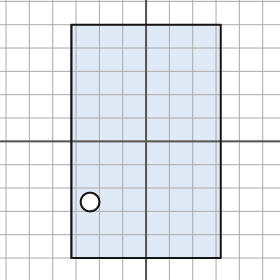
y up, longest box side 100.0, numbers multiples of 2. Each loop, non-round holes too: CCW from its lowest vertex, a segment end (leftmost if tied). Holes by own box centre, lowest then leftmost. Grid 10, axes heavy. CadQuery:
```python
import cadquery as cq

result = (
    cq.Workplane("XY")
    .moveTo(-32.0, -50.0)
    .lineTo(32.0, -50.0)
    .lineTo(32.0, 50.0)
    .lineTo(-32.0, 50.0)
    .close()
    .moveTo(-24.0, -26.0)
    .circle(4.0)
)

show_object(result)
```